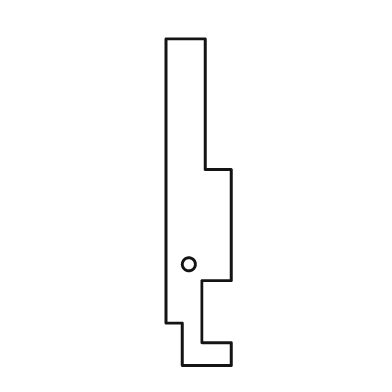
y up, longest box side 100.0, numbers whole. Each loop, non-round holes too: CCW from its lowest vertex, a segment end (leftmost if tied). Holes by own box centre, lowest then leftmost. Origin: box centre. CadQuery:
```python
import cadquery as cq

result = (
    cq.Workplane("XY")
    .moveTo(-5.0, -50.0)
    .lineTo(10.0, -50.0)
    .lineTo(10.0, -43.0)
    .lineTo(1.0, -43.0)
    .lineTo(1.0, -24.0)
    .lineTo(10.0, -24.0)
    .lineTo(10.0, 10.0)
    .lineTo(2.0, 10.0)
    .lineTo(2.0, 50.0)
    .lineTo(-10.0, 50.0)
    .lineTo(-10.0, -37.0)
    .lineTo(-5.0, -37.0)
    .close()
    .moveTo(-3.0, -19.0)
    .circle(2.0)
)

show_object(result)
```